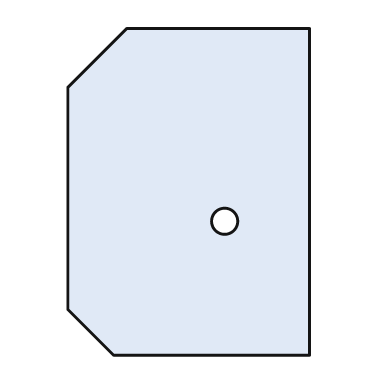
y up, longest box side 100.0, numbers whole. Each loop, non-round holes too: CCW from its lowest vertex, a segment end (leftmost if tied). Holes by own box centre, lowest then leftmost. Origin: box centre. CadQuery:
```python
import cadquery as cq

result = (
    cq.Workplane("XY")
    .moveTo(-23.0, -50.0)
    .lineTo(37.0, -50.0)
    .lineTo(37.0, 50.0)
    .lineTo(-19.0, 50.0)
    .lineTo(-37.0, 32.0)
    .lineTo(-37.0, -36.0)
    .close()
    .moveTo(11.0, -9.0)
    .circle(4.0)
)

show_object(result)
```